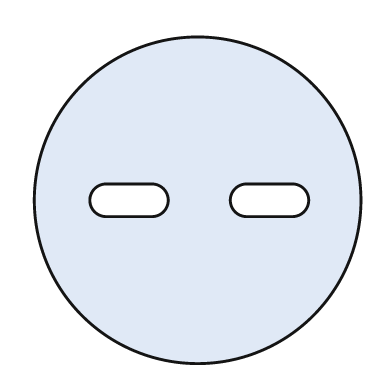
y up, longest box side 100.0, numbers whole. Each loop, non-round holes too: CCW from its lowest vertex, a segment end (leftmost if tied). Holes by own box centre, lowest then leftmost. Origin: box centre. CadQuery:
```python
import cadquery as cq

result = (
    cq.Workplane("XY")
    .moveTo(0.0, 0.0)
    .circle(50.0)
    .moveTo(-28.0, -5.0)
    .lineTo(-14.0, -5.0)
    .threePointArc((-9.0, 0.0), (-14.0, 5.0))
    .lineTo(-28.0, 5.0)
    .threePointArc((-33.0, 0.0), (-28.0, -5.0))
    .close()
    .moveTo(15.0, -5.0)
    .lineTo(29.0, -5.0)
    .threePointArc((34.0, 0.0), (29.0, 5.0))
    .lineTo(15.0, 5.0)
    .threePointArc((10.0, 0.0), (15.0, -5.0))
    .close()
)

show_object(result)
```